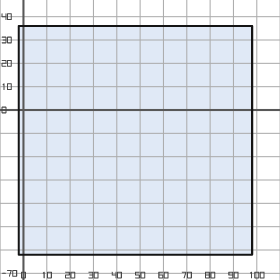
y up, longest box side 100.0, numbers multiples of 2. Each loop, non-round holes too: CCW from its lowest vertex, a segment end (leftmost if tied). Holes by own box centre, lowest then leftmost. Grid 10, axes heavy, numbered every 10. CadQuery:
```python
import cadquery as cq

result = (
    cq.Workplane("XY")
    .moveTo(-2.0, -62.0)
    .lineTo(98.0, -62.0)
    .lineTo(98.0, 36.0)
    .lineTo(-2.0, 36.0)
    .close()
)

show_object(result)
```